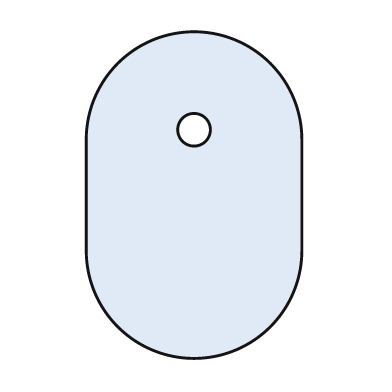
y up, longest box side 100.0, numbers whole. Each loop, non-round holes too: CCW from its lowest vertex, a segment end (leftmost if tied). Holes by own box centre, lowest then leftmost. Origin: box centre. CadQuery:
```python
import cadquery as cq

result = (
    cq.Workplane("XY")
    .moveTo(-33.0, -17.0)
    .threePointArc((0.0, -50.0), (33.0, -17.0))
    .lineTo(33.0, 17.0)
    .threePointArc((0.0, 50.0), (-33.0, 17.0))
    .close()
    .moveTo(0.0, 20.0)
    .circle(5.0)
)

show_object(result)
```